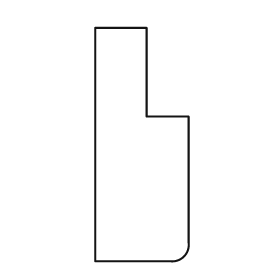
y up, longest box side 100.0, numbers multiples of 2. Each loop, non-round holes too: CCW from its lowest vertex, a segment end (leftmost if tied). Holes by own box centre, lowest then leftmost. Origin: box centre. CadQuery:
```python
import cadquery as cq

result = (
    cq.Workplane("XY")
    .moveTo(-20.0, -50.0)
    .lineTo(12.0, -50.0)
    .threePointArc((18.0, -48.0), (20.0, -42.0))
    .lineTo(20.0, 12.0)
    .lineTo(2.0, 12.0)
    .lineTo(2.0, 50.0)
    .lineTo(-20.0, 50.0)
    .close()
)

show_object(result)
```